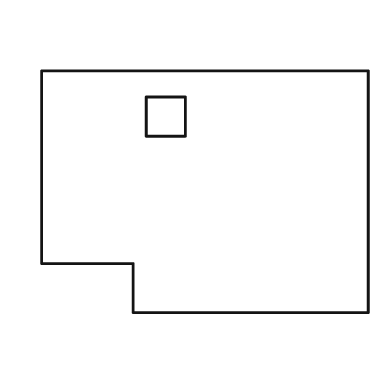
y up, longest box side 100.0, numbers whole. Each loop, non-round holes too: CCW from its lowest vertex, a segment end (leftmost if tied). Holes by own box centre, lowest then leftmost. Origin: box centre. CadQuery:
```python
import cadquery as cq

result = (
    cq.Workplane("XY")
    .moveTo(-22.0, -37.0)
    .lineTo(50.0, -37.0)
    .lineTo(50.0, 37.0)
    .lineTo(-50.0, 37.0)
    .lineTo(-50.0, -22.0)
    .lineTo(-22.0, -22.0)
    .close()
    .moveTo(-18.0, 17.0)
    .lineTo(-6.0, 17.0)
    .lineTo(-6.0, 29.0)
    .lineTo(-18.0, 29.0)
    .close()
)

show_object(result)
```